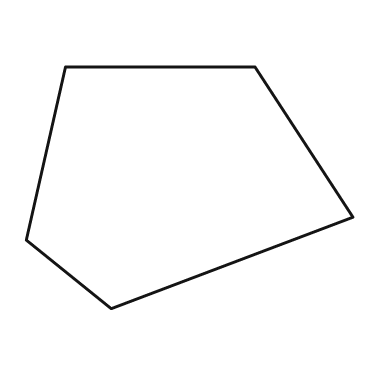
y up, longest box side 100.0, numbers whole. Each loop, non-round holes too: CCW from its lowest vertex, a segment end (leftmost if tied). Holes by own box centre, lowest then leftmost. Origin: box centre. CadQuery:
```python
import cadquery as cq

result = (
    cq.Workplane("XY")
    .moveTo(-24.0, -37.0)
    .lineTo(50.0, -9.0)
    .lineTo(20.0, 37.0)
    .lineTo(-38.0, 37.0)
    .lineTo(-50.0, -16.0)
    .close()
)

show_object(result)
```